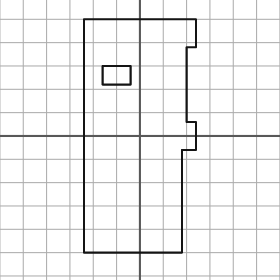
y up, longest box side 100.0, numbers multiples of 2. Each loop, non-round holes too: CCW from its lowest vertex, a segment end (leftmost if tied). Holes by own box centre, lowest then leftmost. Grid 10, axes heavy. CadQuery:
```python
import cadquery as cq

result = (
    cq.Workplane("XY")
    .moveTo(-24.0, -50.0)
    .lineTo(18.0, -50.0)
    .lineTo(18.0, -6.0)
    .lineTo(24.0, -6.0)
    .lineTo(24.0, 6.0)
    .lineTo(20.0, 6.0)
    .lineTo(20.0, 38.0)
    .lineTo(24.0, 38.0)
    .lineTo(24.0, 50.0)
    .lineTo(-24.0, 50.0)
    .close()
    .moveTo(-16.0, 22.0)
    .lineTo(-4.0, 22.0)
    .lineTo(-4.0, 30.0)
    .lineTo(-16.0, 30.0)
    .close()
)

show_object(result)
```